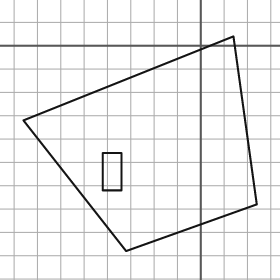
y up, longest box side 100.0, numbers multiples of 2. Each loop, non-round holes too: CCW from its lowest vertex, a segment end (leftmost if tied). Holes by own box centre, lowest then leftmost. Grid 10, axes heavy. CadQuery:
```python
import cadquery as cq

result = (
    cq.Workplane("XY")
    .moveTo(-32.0, -88.0)
    .lineTo(24.0, -68.0)
    .lineTo(14.0, 4.0)
    .lineTo(-76.0, -32.0)
    .close()
    .moveTo(-42.0, -62.0)
    .lineTo(-34.0, -62.0)
    .lineTo(-34.0, -46.0)
    .lineTo(-42.0, -46.0)
    .close()
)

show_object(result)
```